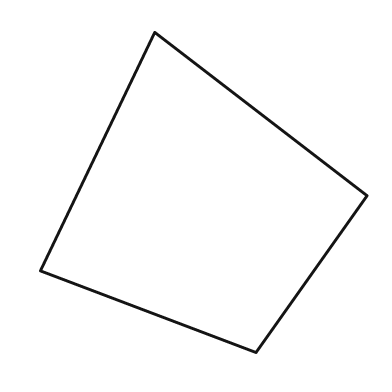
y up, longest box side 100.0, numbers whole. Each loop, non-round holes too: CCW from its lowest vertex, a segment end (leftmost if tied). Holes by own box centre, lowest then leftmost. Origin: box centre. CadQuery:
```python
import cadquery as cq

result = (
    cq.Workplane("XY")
    .moveTo(16.0, -49.0)
    .lineTo(50.0, -1.0)
    .lineTo(-15.0, 49.0)
    .lineTo(-50.0, -24.0)
    .close()
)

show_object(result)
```